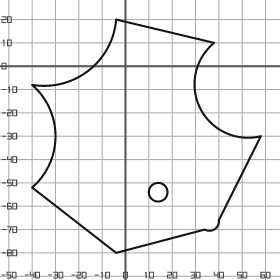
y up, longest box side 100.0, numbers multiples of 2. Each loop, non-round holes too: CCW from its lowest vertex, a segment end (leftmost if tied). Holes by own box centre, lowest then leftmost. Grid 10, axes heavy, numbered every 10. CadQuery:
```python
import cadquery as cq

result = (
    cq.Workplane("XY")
    .moveTo(-4.0, -80.0)
    .lineTo(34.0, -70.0)
    .threePointArc((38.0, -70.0), (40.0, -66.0))
    .lineTo(58.0, -30.0)
    .threePointArc((32.0, -18.0), (38.0, 10.0))
    .lineTo(-4.0, 20.0)
    .threePointArc((-16.0, -2.0), (-40.0, -8.0))
    .threePointArc((-30.0, -30.0), (-40.0, -52.0))
    .close()
    .moveTo(14.0, -54.0)
    .circle(4.0)
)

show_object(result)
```